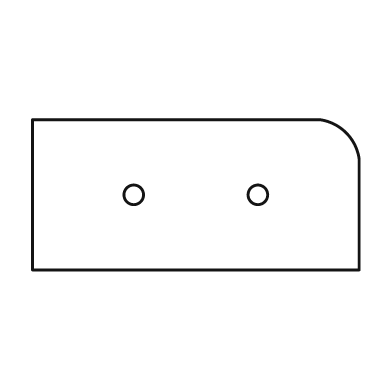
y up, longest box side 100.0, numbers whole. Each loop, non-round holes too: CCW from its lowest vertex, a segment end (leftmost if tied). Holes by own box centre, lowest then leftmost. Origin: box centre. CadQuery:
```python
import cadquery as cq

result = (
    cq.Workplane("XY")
    .moveTo(-50.0, -23.0)
    .lineTo(50.0, -23.0)
    .lineTo(50.0, 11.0)
    .threePointArc((46.0, 19.0), (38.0, 23.0))
    .lineTo(-50.0, 23.0)
    .close()
    .moveTo(-19.0, 0.0)
    .circle(3.0)
    .moveTo(19.0, 0.0)
    .circle(3.0)
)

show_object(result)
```